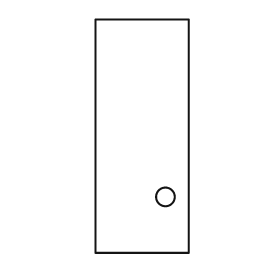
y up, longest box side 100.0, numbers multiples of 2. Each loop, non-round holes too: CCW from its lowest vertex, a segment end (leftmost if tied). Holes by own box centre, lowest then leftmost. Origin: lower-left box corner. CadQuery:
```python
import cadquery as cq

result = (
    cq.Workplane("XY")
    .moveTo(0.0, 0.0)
    .lineTo(40.0, 0.0)
    .lineTo(40.0, 100.0)
    .lineTo(0.0, 100.0)
    .close()
    .moveTo(30.0, 24.0)
    .circle(4.0)
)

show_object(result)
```